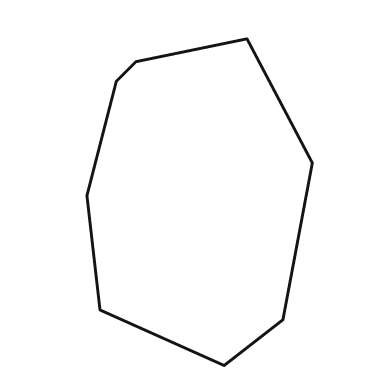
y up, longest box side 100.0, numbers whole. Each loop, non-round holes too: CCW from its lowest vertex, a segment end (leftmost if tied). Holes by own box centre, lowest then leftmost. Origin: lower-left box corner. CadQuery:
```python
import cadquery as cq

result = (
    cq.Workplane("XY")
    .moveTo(42.0, 0.0)
    .lineTo(60.0, 14.0)
    .lineTo(69.0, 62.0)
    .lineTo(49.0, 100.0)
    .lineTo(15.0, 93.0)
    .lineTo(9.0, 87.0)
    .lineTo(0.0, 52.0)
    .lineTo(4.0, 17.0)
    .close()
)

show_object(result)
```